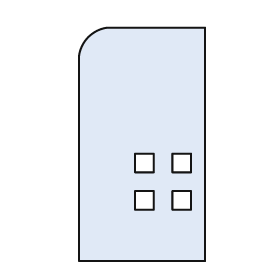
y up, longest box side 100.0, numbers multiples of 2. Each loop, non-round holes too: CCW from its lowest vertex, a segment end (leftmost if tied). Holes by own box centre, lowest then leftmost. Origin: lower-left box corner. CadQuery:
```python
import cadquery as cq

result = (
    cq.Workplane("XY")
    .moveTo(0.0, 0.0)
    .lineTo(54.0, 0.0)
    .lineTo(54.0, 100.0)
    .lineTo(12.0, 100.0)
    .threePointArc((4.0, 96.0), (0.0, 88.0))
    .close()
    .moveTo(24.0, 22.0)
    .lineTo(32.0, 22.0)
    .lineTo(32.0, 30.0)
    .lineTo(24.0, 30.0)
    .close()
    .moveTo(40.0, 22.0)
    .lineTo(48.0, 22.0)
    .lineTo(48.0, 30.0)
    .lineTo(40.0, 30.0)
    .close()
    .moveTo(24.0, 38.0)
    .lineTo(32.0, 38.0)
    .lineTo(32.0, 46.0)
    .lineTo(24.0, 46.0)
    .close()
    .moveTo(40.0, 38.0)
    .lineTo(48.0, 38.0)
    .lineTo(48.0, 46.0)
    .lineTo(40.0, 46.0)
    .close()
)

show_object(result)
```